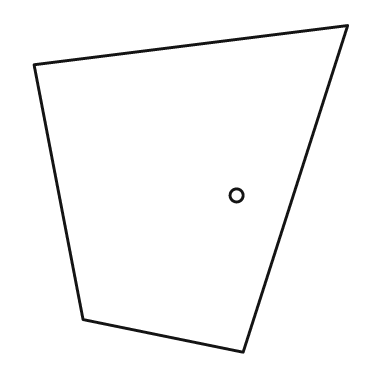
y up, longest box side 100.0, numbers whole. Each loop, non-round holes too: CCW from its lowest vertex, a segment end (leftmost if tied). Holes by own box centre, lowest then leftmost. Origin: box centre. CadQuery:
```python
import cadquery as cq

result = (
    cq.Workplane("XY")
    .moveTo(16.0, -50.0)
    .lineTo(48.0, 50.0)
    .lineTo(-48.0, 38.0)
    .lineTo(-33.0, -40.0)
    .close()
    .moveTo(14.0, -2.0)
    .circle(2.0)
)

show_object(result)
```